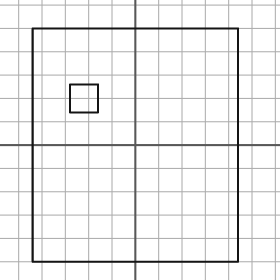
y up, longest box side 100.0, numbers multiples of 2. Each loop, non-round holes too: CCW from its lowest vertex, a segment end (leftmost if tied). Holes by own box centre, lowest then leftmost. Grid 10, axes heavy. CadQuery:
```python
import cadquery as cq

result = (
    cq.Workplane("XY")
    .moveTo(-44.0, -50.0)
    .lineTo(44.0, -50.0)
    .lineTo(44.0, 50.0)
    .lineTo(-44.0, 50.0)
    .close()
    .moveTo(-28.0, 14.0)
    .lineTo(-16.0, 14.0)
    .lineTo(-16.0, 26.0)
    .lineTo(-28.0, 26.0)
    .close()
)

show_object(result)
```